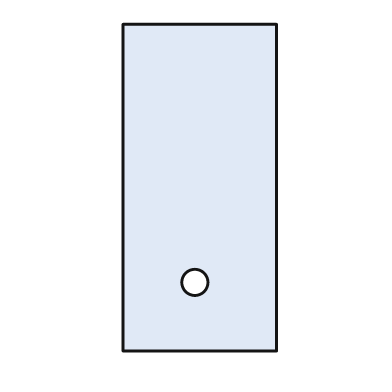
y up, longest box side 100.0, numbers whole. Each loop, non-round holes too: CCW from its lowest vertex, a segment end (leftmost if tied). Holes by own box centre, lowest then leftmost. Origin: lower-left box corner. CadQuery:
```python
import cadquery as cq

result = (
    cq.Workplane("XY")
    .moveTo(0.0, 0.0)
    .lineTo(47.0, 0.0)
    .lineTo(47.0, 100.0)
    .lineTo(0.0, 100.0)
    .close()
    .moveTo(22.0, 21.0)
    .circle(4.0)
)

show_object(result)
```